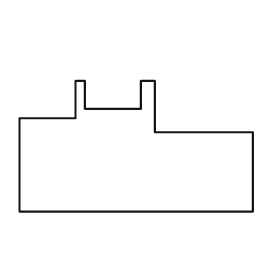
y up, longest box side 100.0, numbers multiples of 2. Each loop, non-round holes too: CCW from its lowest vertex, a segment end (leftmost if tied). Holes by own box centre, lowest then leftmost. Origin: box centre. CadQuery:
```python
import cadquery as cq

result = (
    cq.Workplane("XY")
    .moveTo(-50.0, -28.0)
    .lineTo(50.0, -28.0)
    .lineTo(50.0, 6.0)
    .lineTo(8.0, 6.0)
    .lineTo(8.0, 28.0)
    .lineTo(2.0, 28.0)
    .lineTo(2.0, 16.0)
    .lineTo(-22.0, 16.0)
    .lineTo(-22.0, 28.0)
    .lineTo(-26.0, 28.0)
    .lineTo(-26.0, 12.0)
    .lineTo(-50.0, 12.0)
    .close()
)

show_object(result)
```